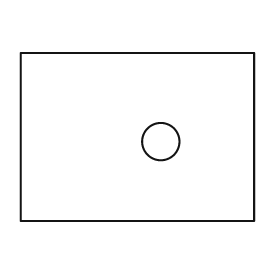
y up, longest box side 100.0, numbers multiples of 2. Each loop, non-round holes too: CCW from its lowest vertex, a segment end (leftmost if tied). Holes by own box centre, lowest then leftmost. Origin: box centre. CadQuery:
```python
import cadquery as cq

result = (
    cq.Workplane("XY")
    .moveTo(-50.0, -36.0)
    .lineTo(50.0, -36.0)
    .lineTo(50.0, 36.0)
    .lineTo(-50.0, 36.0)
    .close()
    .moveTo(10.0, -2.0)
    .circle(8.0)
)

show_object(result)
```